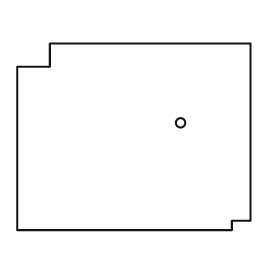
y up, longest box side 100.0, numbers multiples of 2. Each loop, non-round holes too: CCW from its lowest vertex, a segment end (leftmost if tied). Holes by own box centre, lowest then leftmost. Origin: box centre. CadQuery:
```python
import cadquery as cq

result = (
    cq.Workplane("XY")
    .moveTo(-50.0, -40.0)
    .lineTo(42.0, -40.0)
    .lineTo(42.0, -36.0)
    .lineTo(50.0, -36.0)
    .lineTo(50.0, 40.0)
    .lineTo(-36.0, 40.0)
    .lineTo(-36.0, 30.0)
    .lineTo(-50.0, 30.0)
    .close()
    .moveTo(20.0, 6.0)
    .circle(2.0)
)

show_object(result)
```